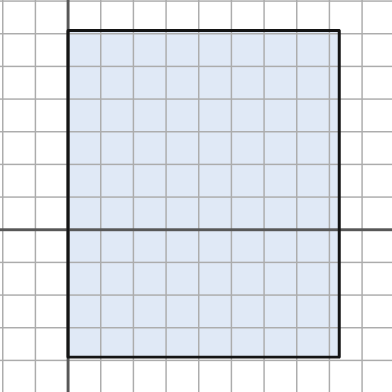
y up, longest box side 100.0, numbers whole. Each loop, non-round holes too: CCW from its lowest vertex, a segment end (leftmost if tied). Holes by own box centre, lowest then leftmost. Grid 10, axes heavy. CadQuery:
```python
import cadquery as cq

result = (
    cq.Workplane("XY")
    .moveTo(0.0, -39.0)
    .lineTo(83.0, -39.0)
    .lineTo(83.0, 61.0)
    .lineTo(0.0, 61.0)
    .close()
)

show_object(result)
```